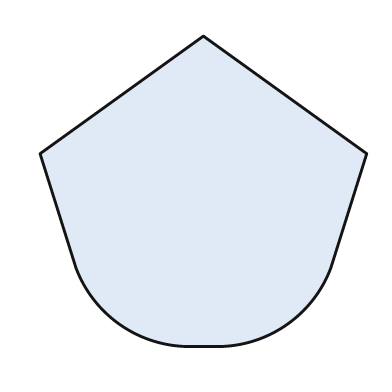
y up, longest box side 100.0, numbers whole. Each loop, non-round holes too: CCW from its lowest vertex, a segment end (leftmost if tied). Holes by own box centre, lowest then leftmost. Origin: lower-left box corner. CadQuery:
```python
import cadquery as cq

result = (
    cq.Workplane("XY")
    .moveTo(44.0, 0.0)
    .lineTo(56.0, 0.0)
    .threePointArc((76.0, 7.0), (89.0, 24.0))
    .lineTo(100.0, 59.0)
    .lineTo(50.0, 95.0)
    .lineTo(0.0, 59.0)
    .lineTo(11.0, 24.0)
    .threePointArc((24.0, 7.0), (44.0, 0.0))
    .close()
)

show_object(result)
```